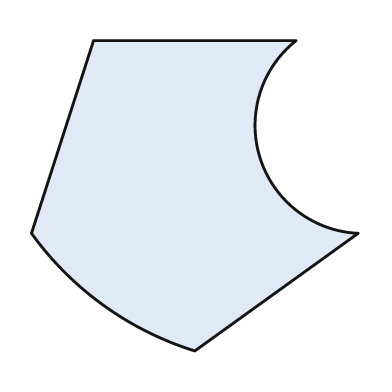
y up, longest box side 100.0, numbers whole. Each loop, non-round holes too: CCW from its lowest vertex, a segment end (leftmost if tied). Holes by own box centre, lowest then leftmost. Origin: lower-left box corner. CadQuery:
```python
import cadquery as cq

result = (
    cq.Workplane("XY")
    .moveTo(50.0, 0.0)
    .lineTo(100.0, 36.0)
    .threePointArc((70.0, 59.0), (81.0, 95.0))
    .lineTo(19.0, 95.0)
    .lineTo(0.0, 36.0)
    .threePointArc((22.0, 14.0), (50.0, 0.0))
    .close()
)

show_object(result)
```